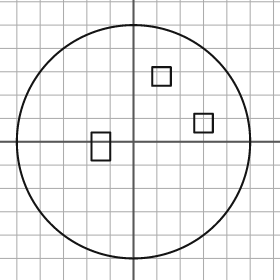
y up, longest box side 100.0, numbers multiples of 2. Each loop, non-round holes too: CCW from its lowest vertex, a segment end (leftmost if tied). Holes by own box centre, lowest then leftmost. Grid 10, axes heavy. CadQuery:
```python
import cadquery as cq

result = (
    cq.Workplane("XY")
    .moveTo(0.0, 0.0)
    .circle(50.0)
    .moveTo(-18.0, -8.0)
    .lineTo(-10.0, -8.0)
    .lineTo(-10.0, 4.0)
    .lineTo(-18.0, 4.0)
    .close()
    .moveTo(26.0, 4.0)
    .lineTo(34.0, 4.0)
    .lineTo(34.0, 12.0)
    .lineTo(26.0, 12.0)
    .close()
    .moveTo(8.0, 24.0)
    .lineTo(16.0, 24.0)
    .lineTo(16.0, 32.0)
    .lineTo(8.0, 32.0)
    .close()
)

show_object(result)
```